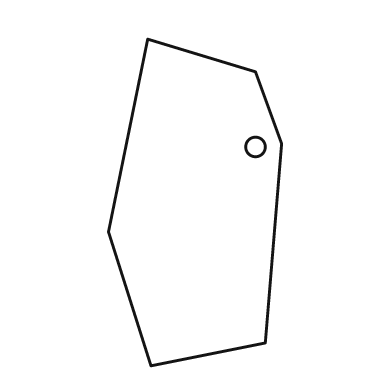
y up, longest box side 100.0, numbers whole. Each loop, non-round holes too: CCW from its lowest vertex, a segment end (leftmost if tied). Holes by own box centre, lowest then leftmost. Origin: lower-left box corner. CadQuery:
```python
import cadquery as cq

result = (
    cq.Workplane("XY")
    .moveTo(13.0, 0.0)
    .lineTo(48.0, 7.0)
    .lineTo(53.0, 68.0)
    .lineTo(45.0, 90.0)
    .lineTo(12.0, 100.0)
    .lineTo(0.0, 41.0)
    .close()
    .moveTo(45.0, 67.0)
    .circle(3.0)
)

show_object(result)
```